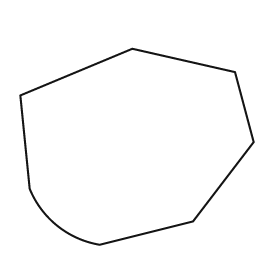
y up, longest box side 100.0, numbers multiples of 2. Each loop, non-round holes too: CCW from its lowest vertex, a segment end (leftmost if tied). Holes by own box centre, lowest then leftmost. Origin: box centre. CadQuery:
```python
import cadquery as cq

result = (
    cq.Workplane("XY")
    .moveTo(-16.0, -42.0)
    .lineTo(24.0, -32.0)
    .lineTo(50.0, 2.0)
    .lineTo(42.0, 32.0)
    .lineTo(-2.0, 42.0)
    .lineTo(-50.0, 22.0)
    .lineTo(-46.0, -18.0)
    .threePointArc((-34.0, -34.0), (-16.0, -42.0))
    .close()
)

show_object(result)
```